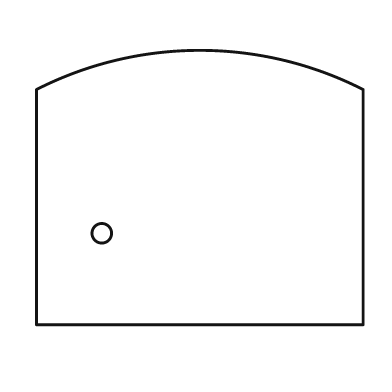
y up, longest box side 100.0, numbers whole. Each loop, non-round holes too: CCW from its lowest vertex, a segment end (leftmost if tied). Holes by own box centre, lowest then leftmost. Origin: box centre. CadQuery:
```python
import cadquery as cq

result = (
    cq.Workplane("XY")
    .moveTo(-50.0, -42.0)
    .lineTo(50.0, -42.0)
    .lineTo(50.0, 30.0)
    .threePointArc((0.0, 42.0), (-50.0, 30.0))
    .close()
    .moveTo(-30.0, -14.0)
    .circle(3.0)
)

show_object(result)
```